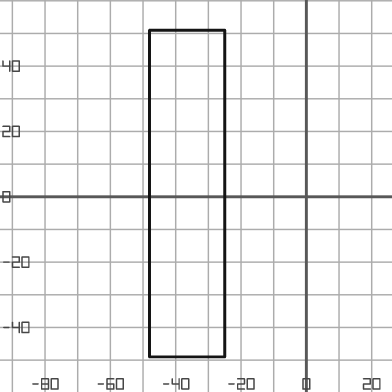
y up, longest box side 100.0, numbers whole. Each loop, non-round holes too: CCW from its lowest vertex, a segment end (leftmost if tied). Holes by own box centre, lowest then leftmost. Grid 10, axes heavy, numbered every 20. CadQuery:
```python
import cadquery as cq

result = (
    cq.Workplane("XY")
    .moveTo(-48.0, -49.0)
    .lineTo(-25.0, -49.0)
    .lineTo(-25.0, 51.0)
    .lineTo(-48.0, 51.0)
    .close()
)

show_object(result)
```